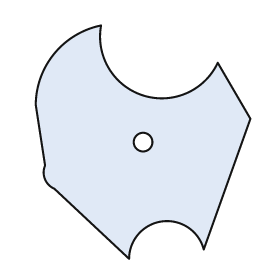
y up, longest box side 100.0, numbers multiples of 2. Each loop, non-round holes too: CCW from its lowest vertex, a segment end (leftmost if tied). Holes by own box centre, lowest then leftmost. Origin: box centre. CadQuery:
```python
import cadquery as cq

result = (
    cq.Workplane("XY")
    .moveTo(-6.0, -50.0)
    .threePointArc((8.0, -34.0), (26.0, -46.0))
    .lineTo(46.0, 10.0)
    .lineTo(32.0, 34.0)
    .threePointArc((0.0, 20.0), (-18.0, 50.0))
    .threePointArc((-38.0, 38.0), (-46.0, 16.0))
    .lineTo(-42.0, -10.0)
    .threePointArc((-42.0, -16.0), (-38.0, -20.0))
    .close()
    .moveTo(0.0, 0.0)
    .circle(4.0)
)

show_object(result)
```